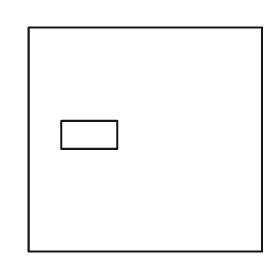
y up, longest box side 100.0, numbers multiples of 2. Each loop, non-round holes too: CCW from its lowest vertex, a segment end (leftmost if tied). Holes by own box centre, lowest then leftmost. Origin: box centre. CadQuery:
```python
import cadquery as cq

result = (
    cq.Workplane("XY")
    .moveTo(-50.0, -48.0)
    .lineTo(50.0, -48.0)
    .lineTo(50.0, 48.0)
    .lineTo(-50.0, 48.0)
    .close()
    .moveTo(-36.0, -4.0)
    .lineTo(-12.0, -4.0)
    .lineTo(-12.0, 8.0)
    .lineTo(-36.0, 8.0)
    .close()
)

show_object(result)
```